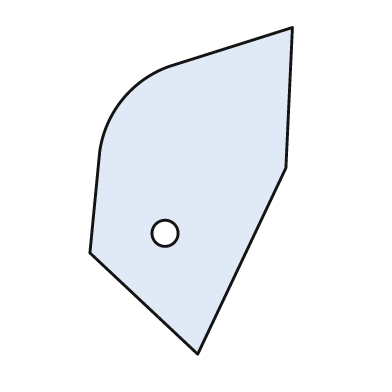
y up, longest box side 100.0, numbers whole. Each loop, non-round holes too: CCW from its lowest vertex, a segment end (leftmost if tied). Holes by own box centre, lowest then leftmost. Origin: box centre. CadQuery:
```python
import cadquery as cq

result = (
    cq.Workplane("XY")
    .moveTo(2.0, -50.0)
    .lineTo(29.0, 7.0)
    .lineTo(31.0, 50.0)
    .lineTo(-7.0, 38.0)
    .threePointArc((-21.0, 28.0), (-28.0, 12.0))
    .lineTo(-31.0, -19.0)
    .close()
    .moveTo(-8.0, -13.0)
    .circle(4.0)
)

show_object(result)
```